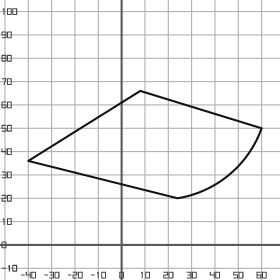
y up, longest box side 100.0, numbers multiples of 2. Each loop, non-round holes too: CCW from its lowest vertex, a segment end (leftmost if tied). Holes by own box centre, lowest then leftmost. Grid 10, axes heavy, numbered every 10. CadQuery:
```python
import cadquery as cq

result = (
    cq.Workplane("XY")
    .moveTo(24.0, 20.0)
    .threePointArc((46.0, 30.0), (60.0, 50.0))
    .lineTo(8.0, 66.0)
    .lineTo(-40.0, 36.0)
    .close()
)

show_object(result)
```